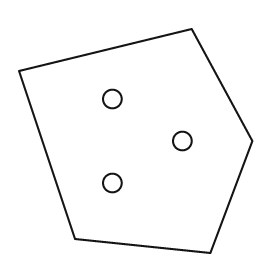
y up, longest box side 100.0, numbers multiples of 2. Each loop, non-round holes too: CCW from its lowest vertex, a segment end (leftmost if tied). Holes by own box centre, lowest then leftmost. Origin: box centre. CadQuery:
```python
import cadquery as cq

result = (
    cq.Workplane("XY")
    .moveTo(32.0, -48.0)
    .lineTo(50.0, 0.0)
    .lineTo(24.0, 48.0)
    .lineTo(-50.0, 30.0)
    .lineTo(-26.0, -42.0)
    .close()
    .moveTo(-10.0, -18.0)
    .circle(4.0)
    .moveTo(20.0, 0.0)
    .circle(4.0)
    .moveTo(-10.0, 18.0)
    .circle(4.0)
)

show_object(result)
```